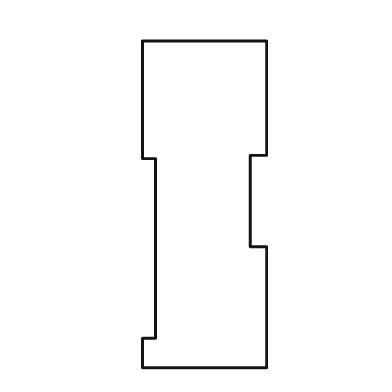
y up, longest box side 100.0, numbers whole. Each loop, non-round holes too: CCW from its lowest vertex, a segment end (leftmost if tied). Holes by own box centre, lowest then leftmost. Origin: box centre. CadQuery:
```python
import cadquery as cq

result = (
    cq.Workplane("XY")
    .moveTo(-19.0, -50.0)
    .lineTo(19.0, -50.0)
    .lineTo(19.0, -13.0)
    .lineTo(14.0, -13.0)
    .lineTo(14.0, 15.0)
    .lineTo(19.0, 15.0)
    .lineTo(19.0, 50.0)
    .lineTo(-19.0, 50.0)
    .lineTo(-19.0, 14.0)
    .lineTo(-15.0, 14.0)
    .lineTo(-15.0, -41.0)
    .lineTo(-19.0, -41.0)
    .close()
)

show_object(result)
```